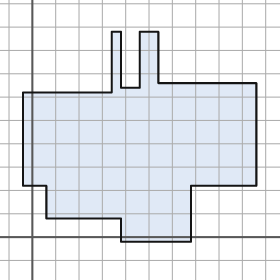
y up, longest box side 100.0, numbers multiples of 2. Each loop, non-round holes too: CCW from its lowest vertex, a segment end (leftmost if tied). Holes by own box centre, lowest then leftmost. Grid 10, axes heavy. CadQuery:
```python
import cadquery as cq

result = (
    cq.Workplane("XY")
    .moveTo(38.0, -2.0)
    .lineTo(68.0, -2.0)
    .lineTo(68.0, 22.0)
    .lineTo(96.0, 22.0)
    .lineTo(96.0, 66.0)
    .lineTo(54.0, 66.0)
    .lineTo(54.0, 88.0)
    .lineTo(46.0, 88.0)
    .lineTo(46.0, 64.0)
    .lineTo(38.0, 64.0)
    .lineTo(38.0, 88.0)
    .lineTo(34.0, 88.0)
    .lineTo(34.0, 62.0)
    .lineTo(-4.0, 62.0)
    .lineTo(-4.0, 22.0)
    .lineTo(6.0, 22.0)
    .lineTo(6.0, 8.0)
    .lineTo(38.0, 8.0)
    .close()
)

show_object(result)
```